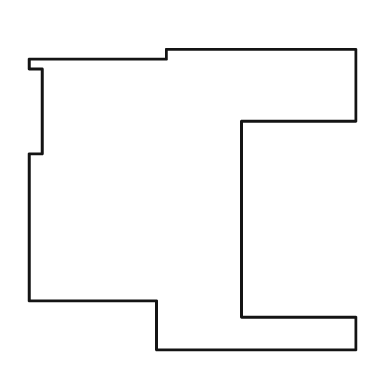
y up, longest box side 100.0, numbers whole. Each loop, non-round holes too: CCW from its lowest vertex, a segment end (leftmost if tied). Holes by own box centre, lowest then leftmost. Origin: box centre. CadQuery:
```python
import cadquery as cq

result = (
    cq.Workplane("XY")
    .moveTo(-11.0, -46.0)
    .lineTo(50.0, -46.0)
    .lineTo(50.0, -36.0)
    .lineTo(15.0, -36.0)
    .lineTo(15.0, 24.0)
    .lineTo(50.0, 24.0)
    .lineTo(50.0, 46.0)
    .lineTo(-8.0, 46.0)
    .lineTo(-8.0, 43.0)
    .lineTo(-50.0, 43.0)
    .lineTo(-50.0, 40.0)
    .lineTo(-46.0, 40.0)
    .lineTo(-46.0, 14.0)
    .lineTo(-50.0, 14.0)
    .lineTo(-50.0, -31.0)
    .lineTo(-11.0, -31.0)
    .close()
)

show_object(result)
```